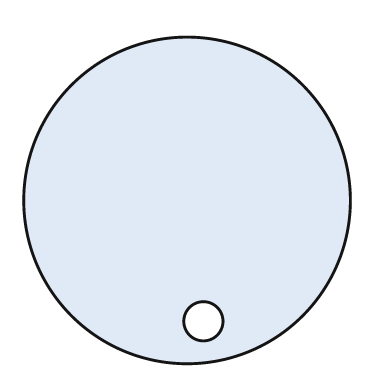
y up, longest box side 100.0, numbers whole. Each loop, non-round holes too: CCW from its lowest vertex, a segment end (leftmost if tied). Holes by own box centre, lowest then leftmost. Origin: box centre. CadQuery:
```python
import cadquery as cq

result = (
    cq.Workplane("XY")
    .moveTo(0.0, 0.0)
    .circle(50.0)
    .moveTo(5.0, -37.0)
    .circle(6.0)
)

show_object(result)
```